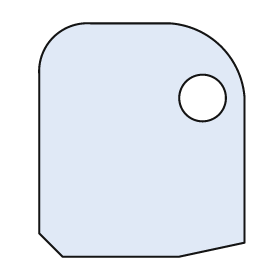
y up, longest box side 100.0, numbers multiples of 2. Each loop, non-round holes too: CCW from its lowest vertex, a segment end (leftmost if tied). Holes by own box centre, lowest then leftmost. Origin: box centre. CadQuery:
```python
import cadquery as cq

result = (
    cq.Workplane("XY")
    .moveTo(-34.0, -50.0)
    .lineTo(16.0, -50.0)
    .lineTo(44.0, -44.0)
    .lineTo(44.0, 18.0)
    .threePointArc((34.0, 40.0), (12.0, 50.0))
    .lineTo(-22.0, 50.0)
    .threePointArc((-38.0, 44.0), (-44.0, 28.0))
    .lineTo(-44.0, -40.0)
    .close()
    .moveTo(26.0, 18.0)
    .circle(10.0)
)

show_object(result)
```